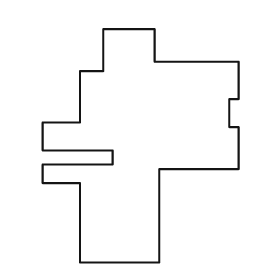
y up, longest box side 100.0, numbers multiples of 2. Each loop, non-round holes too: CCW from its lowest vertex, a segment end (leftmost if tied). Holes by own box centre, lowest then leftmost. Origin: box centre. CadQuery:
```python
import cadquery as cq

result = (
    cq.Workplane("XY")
    .moveTo(-26.0, -50.0)
    .lineTo(8.0, -50.0)
    .lineTo(8.0, -10.0)
    .lineTo(42.0, -10.0)
    .lineTo(42.0, 8.0)
    .lineTo(38.0, 8.0)
    .lineTo(38.0, 20.0)
    .lineTo(42.0, 20.0)
    .lineTo(42.0, 36.0)
    .lineTo(6.0, 36.0)
    .lineTo(6.0, 50.0)
    .lineTo(-16.0, 50.0)
    .lineTo(-16.0, 32.0)
    .lineTo(-26.0, 32.0)
    .lineTo(-26.0, 10.0)
    .lineTo(-42.0, 10.0)
    .lineTo(-42.0, -2.0)
    .lineTo(-12.0, -2.0)
    .lineTo(-12.0, -8.0)
    .lineTo(-42.0, -8.0)
    .lineTo(-42.0, -16.0)
    .lineTo(-26.0, -16.0)
    .close()
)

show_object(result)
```